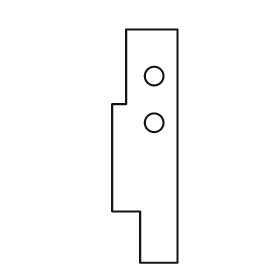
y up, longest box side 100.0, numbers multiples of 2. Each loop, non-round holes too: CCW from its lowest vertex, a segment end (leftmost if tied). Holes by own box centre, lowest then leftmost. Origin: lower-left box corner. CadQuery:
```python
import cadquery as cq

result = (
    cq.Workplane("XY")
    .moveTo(12.0, 0.0)
    .lineTo(28.0, 0.0)
    .lineTo(28.0, 100.0)
    .lineTo(6.0, 100.0)
    .lineTo(6.0, 68.0)
    .lineTo(0.0, 68.0)
    .lineTo(0.0, 22.0)
    .lineTo(12.0, 22.0)
    .close()
    .moveTo(18.0, 60.0)
    .circle(4.0)
    .moveTo(18.0, 80.0)
    .circle(4.0)
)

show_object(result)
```